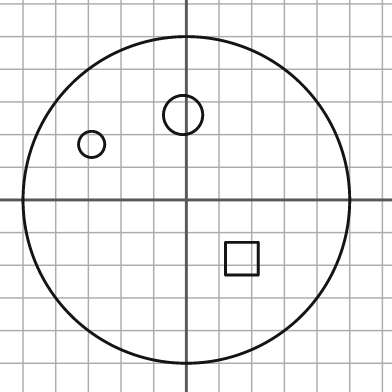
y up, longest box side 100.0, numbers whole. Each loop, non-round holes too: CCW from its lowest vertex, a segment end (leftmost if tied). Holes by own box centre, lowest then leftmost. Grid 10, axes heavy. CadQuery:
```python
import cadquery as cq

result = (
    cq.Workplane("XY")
    .moveTo(0.0, 0.0)
    .circle(50.0)
    .moveTo(12.0, -23.0)
    .lineTo(22.0, -23.0)
    .lineTo(22.0, -13.0)
    .lineTo(12.0, -13.0)
    .close()
    .moveTo(-29.0, 17.0)
    .circle(4.0)
    .moveTo(-1.0, 26.0)
    .circle(6.0)
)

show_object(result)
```